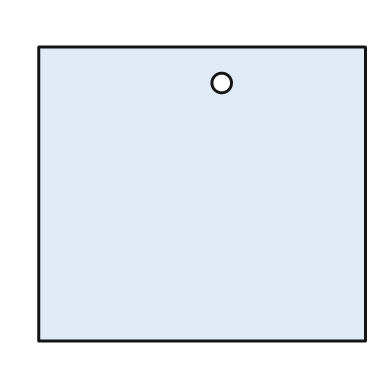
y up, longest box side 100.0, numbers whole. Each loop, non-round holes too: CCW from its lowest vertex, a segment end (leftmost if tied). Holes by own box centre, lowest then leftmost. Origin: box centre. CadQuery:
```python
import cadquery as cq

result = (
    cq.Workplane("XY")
    .moveTo(-50.0, -45.0)
    .lineTo(50.0, -45.0)
    .lineTo(50.0, 45.0)
    .lineTo(-50.0, 45.0)
    .close()
    .moveTo(6.0, 34.0)
    .circle(3.0)
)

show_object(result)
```